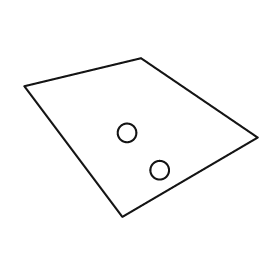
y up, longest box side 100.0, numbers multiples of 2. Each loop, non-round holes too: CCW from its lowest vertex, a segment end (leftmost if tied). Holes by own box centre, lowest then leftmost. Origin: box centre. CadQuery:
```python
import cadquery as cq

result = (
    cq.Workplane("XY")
    .moveTo(-8.0, -34.0)
    .lineTo(50.0, 0.0)
    .lineTo(0.0, 34.0)
    .lineTo(-50.0, 22.0)
    .close()
    .moveTo(8.0, -14.0)
    .circle(4.0)
    .moveTo(-6.0, 2.0)
    .circle(4.0)
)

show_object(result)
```